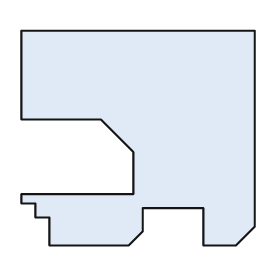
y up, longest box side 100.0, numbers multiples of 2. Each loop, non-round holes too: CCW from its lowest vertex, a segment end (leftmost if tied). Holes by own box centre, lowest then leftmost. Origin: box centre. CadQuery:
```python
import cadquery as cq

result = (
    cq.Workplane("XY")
    .moveTo(-38.0, -46.0)
    .lineTo(-4.0, -46.0)
    .lineTo(2.0, -40.0)
    .lineTo(2.0, -30.0)
    .lineTo(28.0, -30.0)
    .lineTo(28.0, -46.0)
    .lineTo(42.0, -46.0)
    .lineTo(50.0, -38.0)
    .lineTo(50.0, 46.0)
    .lineTo(-50.0, 46.0)
    .lineTo(-50.0, 8.0)
    .lineTo(-16.0, 8.0)
    .lineTo(-2.0, -6.0)
    .lineTo(-2.0, -24.0)
    .lineTo(-50.0, -24.0)
    .lineTo(-50.0, -28.0)
    .lineTo(-44.0, -28.0)
    .lineTo(-44.0, -34.0)
    .lineTo(-38.0, -34.0)
    .close()
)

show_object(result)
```